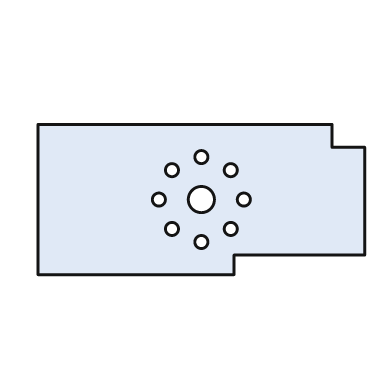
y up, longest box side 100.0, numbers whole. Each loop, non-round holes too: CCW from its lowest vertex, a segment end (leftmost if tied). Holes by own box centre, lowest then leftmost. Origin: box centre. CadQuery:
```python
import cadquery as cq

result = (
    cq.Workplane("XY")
    .moveTo(-50.0, -23.0)
    .lineTo(10.0, -23.0)
    .lineTo(10.0, -17.0)
    .lineTo(50.0, -17.0)
    .lineTo(50.0, 16.0)
    .lineTo(40.0, 16.0)
    .lineTo(40.0, 23.0)
    .lineTo(-50.0, 23.0)
    .close()
    .moveTo(0.0, -13.0)
    .circle(2.0)
    .moveTo(-9.0, -9.0)
    .circle(2.0)
    .moveTo(9.0, -9.0)
    .circle(2.0)
    .moveTo(-13.0, 0.0)
    .circle(2.0)
    .moveTo(0.0, 0.0)
    .circle(4.0)
    .moveTo(13.0, 0.0)
    .circle(2.0)
    .moveTo(-9.0, 9.0)
    .circle(2.0)
    .moveTo(9.0, 9.0)
    .circle(2.0)
    .moveTo(0.0, 13.0)
    .circle(2.0)
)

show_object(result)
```